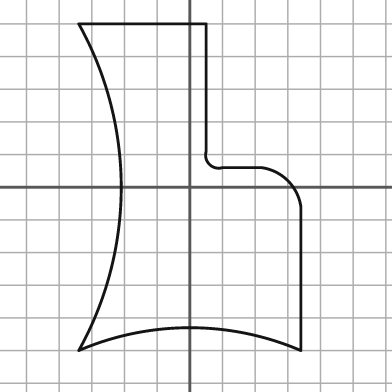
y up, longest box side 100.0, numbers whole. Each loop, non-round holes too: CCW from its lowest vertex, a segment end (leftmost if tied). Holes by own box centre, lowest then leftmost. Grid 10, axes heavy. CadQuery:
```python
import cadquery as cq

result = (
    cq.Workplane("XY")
    .moveTo(-34.0, -50.0)
    .threePointArc((0.0, -43.0), (34.0, -50.0))
    .lineTo(34.0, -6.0)
    .threePointArc((30.0, 2.0), (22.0, 6.0))
    .lineTo(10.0, 6.0)
    .threePointArc((6.0, 7.0), (5.0, 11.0))
    .lineTo(5.0, 50.0)
    .lineTo(-34.0, 50.0)
    .threePointArc((-21.0, 0.0), (-34.0, -50.0))
    .close()
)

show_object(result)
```